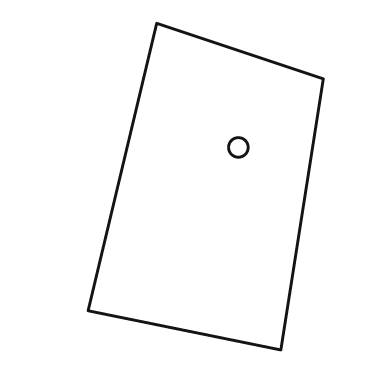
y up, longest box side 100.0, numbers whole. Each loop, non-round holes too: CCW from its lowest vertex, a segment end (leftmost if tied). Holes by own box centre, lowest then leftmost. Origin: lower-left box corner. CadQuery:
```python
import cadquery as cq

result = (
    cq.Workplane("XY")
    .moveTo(59.0, 0.0)
    .lineTo(72.0, 83.0)
    .lineTo(21.0, 100.0)
    .lineTo(0.0, 12.0)
    .close()
    .moveTo(46.0, 62.0)
    .circle(3.0)
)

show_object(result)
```